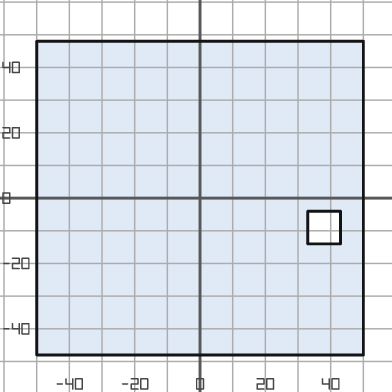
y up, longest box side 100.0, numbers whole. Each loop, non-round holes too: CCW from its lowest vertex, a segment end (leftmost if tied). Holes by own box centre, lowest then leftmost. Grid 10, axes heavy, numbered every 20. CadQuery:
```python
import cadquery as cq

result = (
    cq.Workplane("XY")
    .moveTo(-50.0, -48.0)
    .lineTo(50.0, -48.0)
    .lineTo(50.0, 48.0)
    .lineTo(-50.0, 48.0)
    .close()
    .moveTo(33.0, -14.0)
    .lineTo(43.0, -14.0)
    .lineTo(43.0, -4.0)
    .lineTo(33.0, -4.0)
    .close()
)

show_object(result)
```